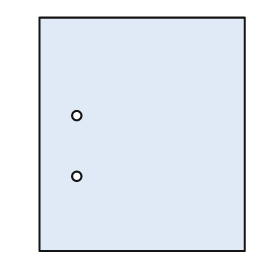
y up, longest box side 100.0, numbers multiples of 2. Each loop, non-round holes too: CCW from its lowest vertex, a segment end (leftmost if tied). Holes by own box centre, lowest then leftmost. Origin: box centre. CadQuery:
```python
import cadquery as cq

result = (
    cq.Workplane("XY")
    .moveTo(-44.0, -50.0)
    .lineTo(44.0, -50.0)
    .lineTo(44.0, 50.0)
    .lineTo(-44.0, 50.0)
    .close()
    .moveTo(-28.0, -18.0)
    .circle(2.0)
    .moveTo(-28.0, 8.0)
    .circle(2.0)
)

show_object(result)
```